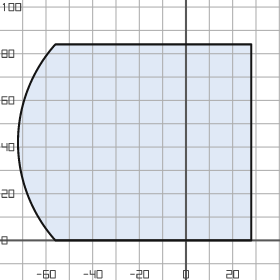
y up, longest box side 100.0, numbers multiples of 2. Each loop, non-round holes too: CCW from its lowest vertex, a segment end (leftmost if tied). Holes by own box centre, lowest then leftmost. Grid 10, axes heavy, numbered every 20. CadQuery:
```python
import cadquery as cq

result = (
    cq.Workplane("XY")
    .moveTo(-56.0, 0.0)
    .lineTo(28.0, 0.0)
    .lineTo(28.0, 84.0)
    .lineTo(-56.0, 84.0)
    .threePointArc((-72.0, 42.0), (-56.0, 0.0))
    .close()
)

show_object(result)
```